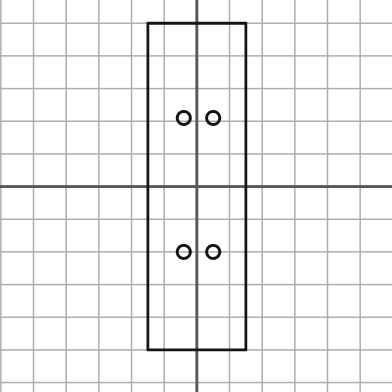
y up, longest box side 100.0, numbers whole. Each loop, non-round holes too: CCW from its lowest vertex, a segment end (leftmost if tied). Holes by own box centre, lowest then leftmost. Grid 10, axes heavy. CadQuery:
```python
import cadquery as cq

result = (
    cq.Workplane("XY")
    .moveTo(-15.0, -50.0)
    .lineTo(15.0, -50.0)
    .lineTo(15.0, 50.0)
    .lineTo(-15.0, 50.0)
    .close()
    .moveTo(-4.0, -20.0)
    .circle(2.0)
    .moveTo(5.0, -20.0)
    .circle(2.0)
    .moveTo(-4.0, 21.0)
    .circle(2.0)
    .moveTo(5.0, 21.0)
    .circle(2.0)
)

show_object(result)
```